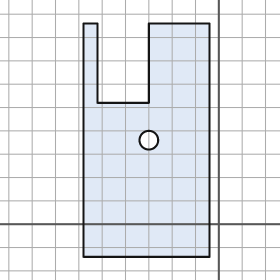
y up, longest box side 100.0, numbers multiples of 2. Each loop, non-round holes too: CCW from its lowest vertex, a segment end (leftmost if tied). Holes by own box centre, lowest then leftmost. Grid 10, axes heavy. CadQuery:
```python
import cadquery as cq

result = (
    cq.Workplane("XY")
    .moveTo(-58.0, -14.0)
    .lineTo(-4.0, -14.0)
    .lineTo(-4.0, 86.0)
    .lineTo(-30.0, 86.0)
    .lineTo(-30.0, 52.0)
    .lineTo(-52.0, 52.0)
    .lineTo(-52.0, 86.0)
    .lineTo(-58.0, 86.0)
    .close()
    .moveTo(-30.0, 36.0)
    .circle(4.0)
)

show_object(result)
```